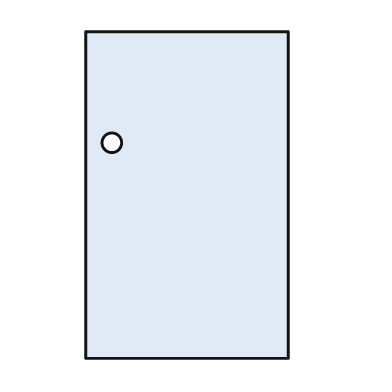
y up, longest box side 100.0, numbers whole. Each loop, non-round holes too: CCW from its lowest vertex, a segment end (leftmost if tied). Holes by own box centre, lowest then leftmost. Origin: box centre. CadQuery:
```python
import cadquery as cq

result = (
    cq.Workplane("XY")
    .moveTo(-31.0, -50.0)
    .lineTo(31.0, -50.0)
    .lineTo(31.0, 50.0)
    .lineTo(-31.0, 50.0)
    .close()
    .moveTo(-23.0, 16.0)
    .circle(3.0)
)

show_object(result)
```